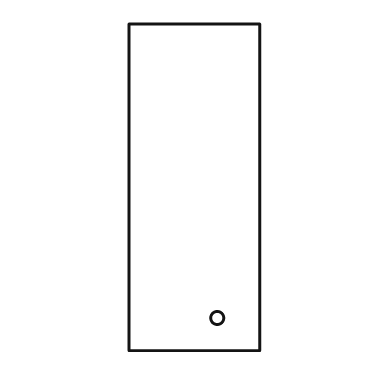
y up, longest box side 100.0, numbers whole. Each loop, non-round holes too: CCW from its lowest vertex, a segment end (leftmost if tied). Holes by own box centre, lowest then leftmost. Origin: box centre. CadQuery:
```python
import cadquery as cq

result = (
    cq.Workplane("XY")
    .moveTo(-20.0, -50.0)
    .lineTo(20.0, -50.0)
    .lineTo(20.0, 50.0)
    .lineTo(-20.0, 50.0)
    .close()
    .moveTo(7.0, -40.0)
    .circle(2.0)
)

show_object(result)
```